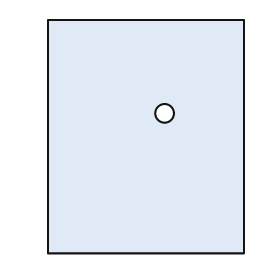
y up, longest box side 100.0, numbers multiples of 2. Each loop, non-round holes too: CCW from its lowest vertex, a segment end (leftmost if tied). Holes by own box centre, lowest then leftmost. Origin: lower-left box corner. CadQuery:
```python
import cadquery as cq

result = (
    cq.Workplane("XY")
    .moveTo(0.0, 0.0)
    .lineTo(84.0, 0.0)
    .lineTo(84.0, 100.0)
    .lineTo(0.0, 100.0)
    .close()
    .moveTo(50.0, 60.0)
    .circle(4.0)
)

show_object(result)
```